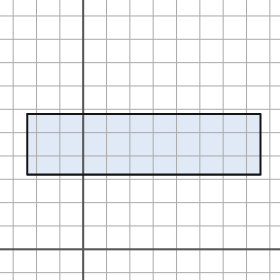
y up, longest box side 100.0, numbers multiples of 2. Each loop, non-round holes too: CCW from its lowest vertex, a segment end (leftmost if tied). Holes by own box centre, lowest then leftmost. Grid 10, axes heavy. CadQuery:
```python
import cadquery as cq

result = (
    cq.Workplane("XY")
    .moveTo(-24.0, 32.0)
    .lineTo(76.0, 32.0)
    .lineTo(76.0, 58.0)
    .lineTo(-24.0, 58.0)
    .close()
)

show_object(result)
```